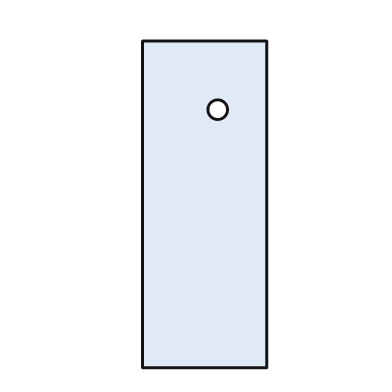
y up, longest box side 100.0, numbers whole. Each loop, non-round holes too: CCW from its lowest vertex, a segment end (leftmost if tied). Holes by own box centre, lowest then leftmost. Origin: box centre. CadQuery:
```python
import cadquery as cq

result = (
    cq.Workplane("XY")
    .moveTo(-19.0, -50.0)
    .lineTo(19.0, -50.0)
    .lineTo(19.0, 50.0)
    .lineTo(-19.0, 50.0)
    .close()
    .moveTo(4.0, 29.0)
    .circle(3.0)
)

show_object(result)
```